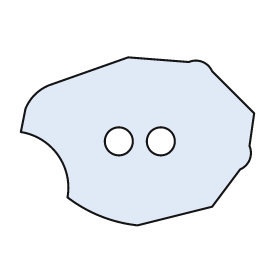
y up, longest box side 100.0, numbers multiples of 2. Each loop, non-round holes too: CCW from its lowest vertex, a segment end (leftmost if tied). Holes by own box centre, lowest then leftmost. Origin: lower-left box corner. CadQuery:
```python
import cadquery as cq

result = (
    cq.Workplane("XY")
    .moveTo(50.0, 0.0)
    .lineTo(82.0, 8.0)
    .lineTo(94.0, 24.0)
    .threePointArc((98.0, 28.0), (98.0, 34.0))
    .lineTo(100.0, 48.0)
    .lineTo(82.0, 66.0)
    .threePointArc((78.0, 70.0), (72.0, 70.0))
    .lineTo(46.0, 72.0)
    .lineTo(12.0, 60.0)
    .threePointArc((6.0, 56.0), (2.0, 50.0))
    .lineTo(0.0, 40.0)
    .threePointArc((16.0, 30.0), (20.0, 12.0))
    .threePointArc((34.0, 4.0), (50.0, 0.0))
    .close()
    .moveTo(42.0, 36.0)
    .circle(6.0)
    .moveTo(60.0, 36.0)
    .circle(6.0)
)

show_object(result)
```